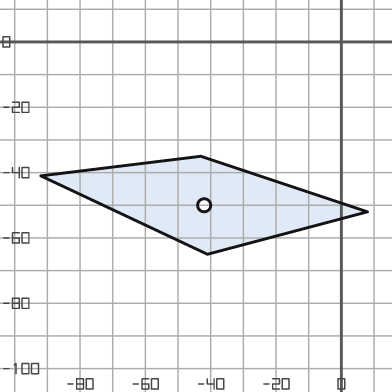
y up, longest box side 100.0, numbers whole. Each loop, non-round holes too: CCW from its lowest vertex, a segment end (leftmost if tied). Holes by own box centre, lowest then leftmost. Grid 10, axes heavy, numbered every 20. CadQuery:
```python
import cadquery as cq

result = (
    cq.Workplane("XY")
    .moveTo(-41.0, -65.0)
    .lineTo(8.0, -52.0)
    .lineTo(-43.0, -35.0)
    .lineTo(-92.0, -41.0)
    .close()
    .moveTo(-42.0, -50.0)
    .circle(2.0)
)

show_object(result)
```